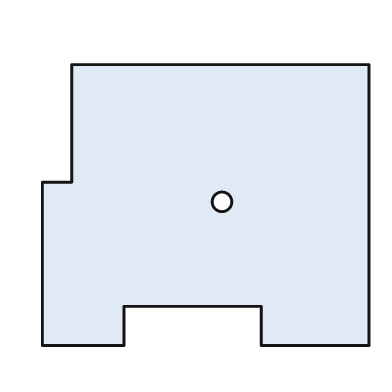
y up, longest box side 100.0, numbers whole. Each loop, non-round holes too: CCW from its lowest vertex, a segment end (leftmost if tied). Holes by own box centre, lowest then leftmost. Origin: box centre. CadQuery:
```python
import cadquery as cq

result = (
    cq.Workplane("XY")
    .moveTo(-50.0, -43.0)
    .lineTo(-25.0, -43.0)
    .lineTo(-25.0, -31.0)
    .lineTo(17.0, -31.0)
    .lineTo(17.0, -43.0)
    .lineTo(50.0, -43.0)
    .lineTo(50.0, 43.0)
    .lineTo(-41.0, 43.0)
    .lineTo(-41.0, 7.0)
    .lineTo(-50.0, 7.0)
    .close()
    .moveTo(5.0, 1.0)
    .circle(3.0)
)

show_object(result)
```